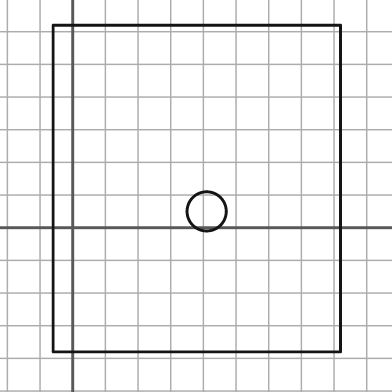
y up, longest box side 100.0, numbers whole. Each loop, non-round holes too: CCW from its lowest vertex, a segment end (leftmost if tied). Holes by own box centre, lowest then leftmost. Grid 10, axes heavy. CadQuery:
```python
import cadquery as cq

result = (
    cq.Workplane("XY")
    .moveTo(-6.0, -38.0)
    .lineTo(82.0, -38.0)
    .lineTo(82.0, 62.0)
    .lineTo(-6.0, 62.0)
    .close()
    .moveTo(41.0, 5.0)
    .circle(6.0)
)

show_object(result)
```